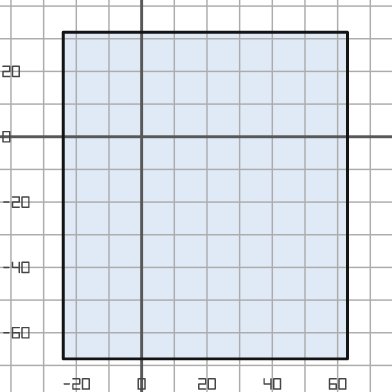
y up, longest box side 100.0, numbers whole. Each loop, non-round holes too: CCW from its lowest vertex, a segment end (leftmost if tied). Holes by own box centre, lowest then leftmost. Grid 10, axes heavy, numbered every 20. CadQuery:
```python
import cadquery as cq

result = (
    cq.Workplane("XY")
    .moveTo(-24.0, -68.0)
    .lineTo(63.0, -68.0)
    .lineTo(63.0, 32.0)
    .lineTo(-24.0, 32.0)
    .close()
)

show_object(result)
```